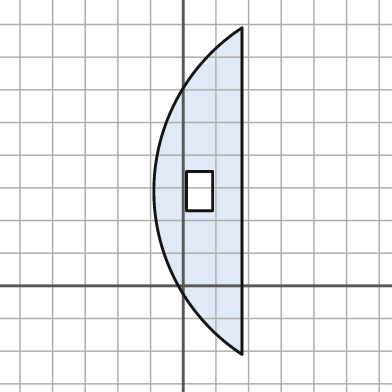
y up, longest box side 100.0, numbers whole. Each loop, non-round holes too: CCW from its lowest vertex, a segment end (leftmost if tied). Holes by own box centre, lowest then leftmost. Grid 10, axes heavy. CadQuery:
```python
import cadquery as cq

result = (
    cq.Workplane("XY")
    .moveTo(18.0, -21.0)
    .lineTo(18.0, 79.0)
    .threePointArc((-9.0, 29.0), (18.0, -21.0))
    .close()
    .moveTo(1.0, 23.0)
    .lineTo(9.0, 23.0)
    .lineTo(9.0, 35.0)
    .lineTo(1.0, 35.0)
    .close()
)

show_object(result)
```